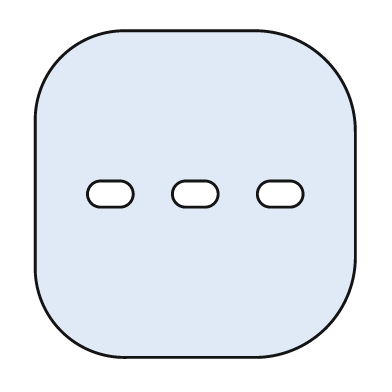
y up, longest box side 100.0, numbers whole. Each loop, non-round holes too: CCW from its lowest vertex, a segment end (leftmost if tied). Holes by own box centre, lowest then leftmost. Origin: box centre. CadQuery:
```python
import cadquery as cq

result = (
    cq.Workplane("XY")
    .moveTo(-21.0, -50.0)
    .lineTo(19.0, -50.0)
    .threePointArc((40.0, -41.0), (49.0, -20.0))
    .lineTo(49.0, 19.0)
    .threePointArc((40.0, 41.0), (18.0, 50.0))
    .lineTo(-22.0, 50.0)
    .threePointArc((-41.0, 42.0), (-49.0, 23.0))
    .lineTo(-49.0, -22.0)
    .threePointArc((-41.0, -42.0), (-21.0, -50.0))
    .close()
    .moveTo(-29.0, -4.0)
    .lineTo(-23.0, -4.0)
    .threePointArc((-19.0, 0.0), (-23.0, 4.0))
    .lineTo(-29.0, 4.0)
    .threePointArc((-33.0, 0.0), (-29.0, -4.0))
    .close()
    .moveTo(-3.0, -4.0)
    .lineTo(3.0, -4.0)
    .threePointArc((7.0, 0.0), (3.0, 4.0))
    .lineTo(-3.0, 4.0)
    .threePointArc((-7.0, 0.0), (-3.0, -4.0))
    .close()
    .moveTo(23.0, -4.0)
    .lineTo(29.0, -4.0)
    .threePointArc((33.0, 0.0), (29.0, 4.0))
    .lineTo(23.0, 4.0)
    .threePointArc((19.0, 0.0), (23.0, -4.0))
    .close()
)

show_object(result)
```